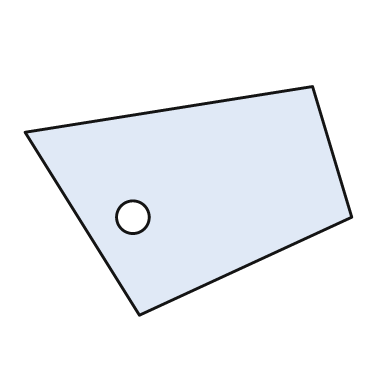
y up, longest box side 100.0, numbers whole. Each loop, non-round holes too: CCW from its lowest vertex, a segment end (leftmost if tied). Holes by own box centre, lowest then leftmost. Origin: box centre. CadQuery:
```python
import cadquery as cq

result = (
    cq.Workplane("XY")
    .moveTo(-15.0, -35.0)
    .lineTo(50.0, -5.0)
    .lineTo(38.0, 35.0)
    .lineTo(-50.0, 21.0)
    .close()
    .moveTo(-17.0, -5.0)
    .circle(5.0)
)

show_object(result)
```